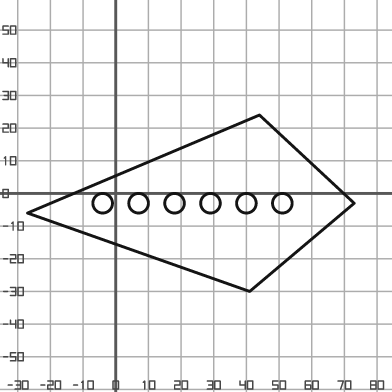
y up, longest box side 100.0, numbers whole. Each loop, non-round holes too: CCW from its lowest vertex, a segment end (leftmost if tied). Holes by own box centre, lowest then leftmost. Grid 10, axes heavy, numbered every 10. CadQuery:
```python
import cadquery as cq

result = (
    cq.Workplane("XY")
    .moveTo(41.0, -30.0)
    .lineTo(73.0, -3.0)
    .lineTo(44.0, 24.0)
    .lineTo(-27.0, -6.0)
    .close()
    .moveTo(-4.0, -3.0)
    .circle(3.0)
    .moveTo(7.0, -3.0)
    .circle(3.0)
    .moveTo(18.0, -3.0)
    .circle(3.0)
    .moveTo(29.0, -3.0)
    .circle(3.0)
    .moveTo(40.0, -3.0)
    .circle(3.0)
    .moveTo(51.0, -3.0)
    .circle(3.0)
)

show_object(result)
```